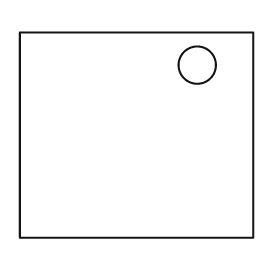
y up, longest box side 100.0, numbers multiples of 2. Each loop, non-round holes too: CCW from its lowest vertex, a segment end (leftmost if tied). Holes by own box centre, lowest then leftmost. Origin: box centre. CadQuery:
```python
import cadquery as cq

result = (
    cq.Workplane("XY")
    .moveTo(-50.0, -44.0)
    .lineTo(50.0, -44.0)
    .lineTo(50.0, 44.0)
    .lineTo(-50.0, 44.0)
    .close()
    .moveTo(26.0, 30.0)
    .circle(8.0)
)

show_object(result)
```